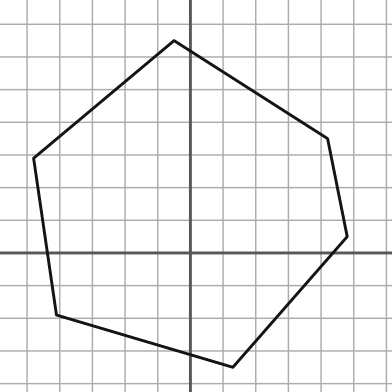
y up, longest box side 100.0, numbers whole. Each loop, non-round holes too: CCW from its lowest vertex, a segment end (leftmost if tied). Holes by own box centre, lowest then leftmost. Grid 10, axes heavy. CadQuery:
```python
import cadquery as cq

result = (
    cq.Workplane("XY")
    .moveTo(13.0, -35.0)
    .lineTo(48.0, 5.0)
    .lineTo(42.0, 35.0)
    .lineTo(-5.0, 65.0)
    .lineTo(-48.0, 29.0)
    .lineTo(-41.0, -19.0)
    .close()
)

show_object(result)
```